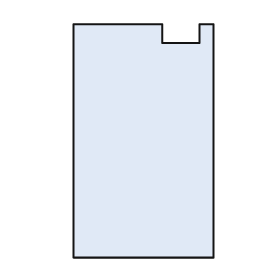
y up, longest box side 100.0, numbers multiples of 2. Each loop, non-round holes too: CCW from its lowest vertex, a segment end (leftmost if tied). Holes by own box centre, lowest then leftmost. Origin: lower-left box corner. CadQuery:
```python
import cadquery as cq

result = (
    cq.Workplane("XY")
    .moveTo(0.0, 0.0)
    .lineTo(60.0, 0.0)
    .lineTo(60.0, 100.0)
    .lineTo(54.0, 100.0)
    .lineTo(54.0, 92.0)
    .lineTo(38.0, 92.0)
    .lineTo(38.0, 100.0)
    .lineTo(0.0, 100.0)
    .close()
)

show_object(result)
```